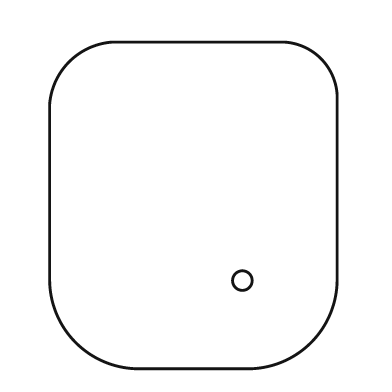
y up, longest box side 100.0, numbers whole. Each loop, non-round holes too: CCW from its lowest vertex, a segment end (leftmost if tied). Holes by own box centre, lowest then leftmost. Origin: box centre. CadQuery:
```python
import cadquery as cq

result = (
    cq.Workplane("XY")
    .moveTo(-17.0, -50.0)
    .lineTo(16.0, -50.0)
    .threePointArc((36.0, -42.0), (44.0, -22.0))
    .lineTo(44.0, 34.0)
    .threePointArc((39.0, 45.0), (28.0, 50.0))
    .lineTo(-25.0, 50.0)
    .threePointArc((-38.0, 44.0), (-44.0, 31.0))
    .lineTo(-44.0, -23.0)
    .threePointArc((-36.0, -42.0), (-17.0, -50.0))
    .close()
    .moveTo(15.0, -23.0)
    .circle(3.0)
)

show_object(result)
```